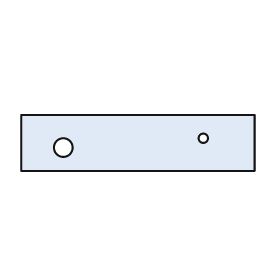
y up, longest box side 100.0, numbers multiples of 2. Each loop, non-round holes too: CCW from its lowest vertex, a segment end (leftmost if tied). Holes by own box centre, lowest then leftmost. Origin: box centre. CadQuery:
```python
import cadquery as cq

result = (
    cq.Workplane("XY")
    .moveTo(-50.0, -12.0)
    .lineTo(50.0, -12.0)
    .lineTo(50.0, 12.0)
    .lineTo(-50.0, 12.0)
    .close()
    .moveTo(-32.0, -2.0)
    .circle(4.0)
    .moveTo(28.0, 2.0)
    .circle(2.0)
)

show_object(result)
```